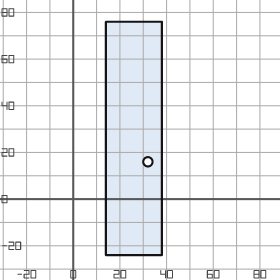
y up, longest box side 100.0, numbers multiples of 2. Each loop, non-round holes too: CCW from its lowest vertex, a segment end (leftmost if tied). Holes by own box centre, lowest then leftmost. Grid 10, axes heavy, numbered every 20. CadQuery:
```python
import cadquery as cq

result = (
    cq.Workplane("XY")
    .moveTo(14.0, -24.0)
    .lineTo(38.0, -24.0)
    .lineTo(38.0, 76.0)
    .lineTo(14.0, 76.0)
    .close()
    .moveTo(32.0, 16.0)
    .circle(2.0)
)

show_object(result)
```